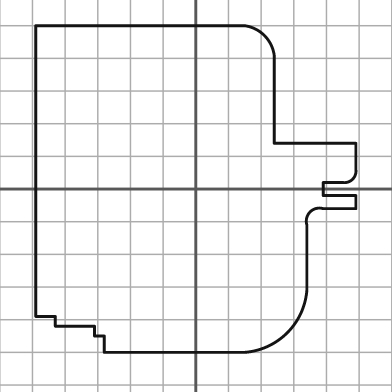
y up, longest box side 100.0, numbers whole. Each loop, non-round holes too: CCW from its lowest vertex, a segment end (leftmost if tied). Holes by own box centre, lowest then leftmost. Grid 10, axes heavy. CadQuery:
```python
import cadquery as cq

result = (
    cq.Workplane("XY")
    .moveTo(-28.0, -50.0)
    .lineTo(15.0, -50.0)
    .threePointArc((28.0, -44.0), (34.0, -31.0))
    .lineTo(34.0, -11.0)
    .threePointArc((35.0, -7.0), (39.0, -6.0))
    .lineTo(49.0, -6.0)
    .lineTo(49.0, -2.0)
    .lineTo(39.0, -2.0)
    .lineTo(39.0, 2.0)
    .lineTo(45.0, 2.0)
    .threePointArc((48.0, 3.0), (49.0, 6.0))
    .lineTo(49.0, 14.0)
    .lineTo(24.0, 14.0)
    .lineTo(24.0, 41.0)
    .threePointArc((21.0, 47.0), (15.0, 50.0))
    .lineTo(-49.0, 50.0)
    .lineTo(-49.0, -39.0)
    .lineTo(-43.0, -39.0)
    .lineTo(-43.0, -42.0)
    .lineTo(-31.0, -42.0)
    .lineTo(-31.0, -45.0)
    .lineTo(-28.0, -45.0)
    .close()
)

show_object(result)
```